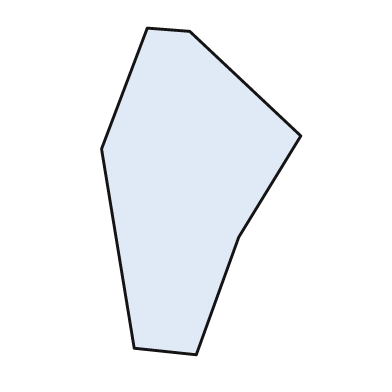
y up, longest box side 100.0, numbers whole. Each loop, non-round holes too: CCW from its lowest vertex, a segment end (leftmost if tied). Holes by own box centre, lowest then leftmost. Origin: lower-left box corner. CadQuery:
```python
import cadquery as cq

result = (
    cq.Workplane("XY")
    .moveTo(29.0, 0.0)
    .lineTo(42.0, 36.0)
    .lineTo(61.0, 67.0)
    .lineTo(27.0, 99.0)
    .lineTo(14.0, 100.0)
    .lineTo(0.0, 63.0)
    .lineTo(10.0, 2.0)
    .close()
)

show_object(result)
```